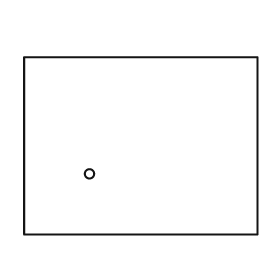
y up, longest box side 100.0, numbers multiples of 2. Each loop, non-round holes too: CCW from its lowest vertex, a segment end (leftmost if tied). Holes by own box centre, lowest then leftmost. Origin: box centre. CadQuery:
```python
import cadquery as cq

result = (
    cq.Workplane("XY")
    .moveTo(-50.0, -38.0)
    .lineTo(50.0, -38.0)
    .lineTo(50.0, 38.0)
    .lineTo(-50.0, 38.0)
    .close()
    .moveTo(-22.0, -12.0)
    .circle(2.0)
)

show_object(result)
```